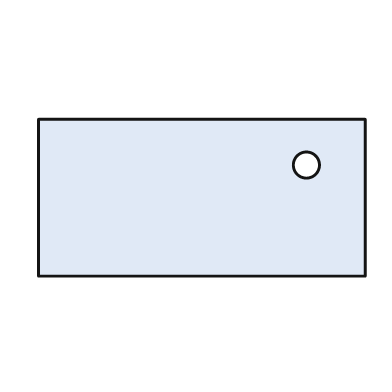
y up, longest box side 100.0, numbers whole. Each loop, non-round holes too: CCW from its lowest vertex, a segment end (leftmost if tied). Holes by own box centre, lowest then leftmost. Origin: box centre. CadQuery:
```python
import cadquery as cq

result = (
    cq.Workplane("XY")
    .moveTo(-50.0, -24.0)
    .lineTo(50.0, -24.0)
    .lineTo(50.0, 24.0)
    .lineTo(-50.0, 24.0)
    .close()
    .moveTo(32.0, 10.0)
    .circle(4.0)
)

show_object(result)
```